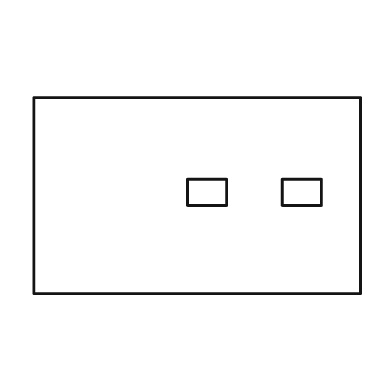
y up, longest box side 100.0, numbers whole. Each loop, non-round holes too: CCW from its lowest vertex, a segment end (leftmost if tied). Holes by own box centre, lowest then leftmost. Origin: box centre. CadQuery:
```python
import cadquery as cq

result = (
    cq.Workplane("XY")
    .moveTo(-50.0, -30.0)
    .lineTo(50.0, -30.0)
    .lineTo(50.0, 30.0)
    .lineTo(-50.0, 30.0)
    .close()
    .moveTo(-3.0, -3.0)
    .lineTo(9.0, -3.0)
    .lineTo(9.0, 5.0)
    .lineTo(-3.0, 5.0)
    .close()
    .moveTo(26.0, -3.0)
    .lineTo(38.0, -3.0)
    .lineTo(38.0, 5.0)
    .lineTo(26.0, 5.0)
    .close()
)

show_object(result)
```